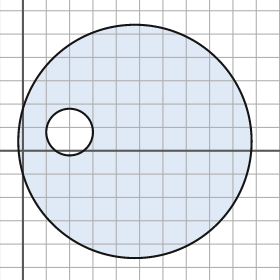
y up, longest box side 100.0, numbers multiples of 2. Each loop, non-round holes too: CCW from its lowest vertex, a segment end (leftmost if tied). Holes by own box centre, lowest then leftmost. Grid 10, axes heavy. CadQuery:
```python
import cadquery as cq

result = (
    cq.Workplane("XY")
    .moveTo(48.0, 4.0)
    .circle(50.0)
    .moveTo(20.0, 8.0)
    .circle(10.0)
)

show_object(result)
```